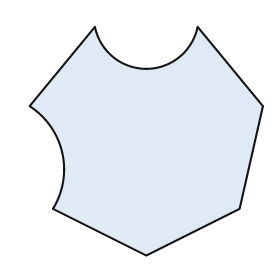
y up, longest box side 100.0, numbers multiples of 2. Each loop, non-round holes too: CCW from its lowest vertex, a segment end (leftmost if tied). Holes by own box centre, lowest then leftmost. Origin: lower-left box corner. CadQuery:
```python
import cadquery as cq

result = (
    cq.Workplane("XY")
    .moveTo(50.0, 0.0)
    .lineTo(90.0, 20.0)
    .lineTo(100.0, 64.0)
    .lineTo(72.0, 98.0)
    .threePointArc((50.0, 80.0), (28.0, 98.0))
    .lineTo(0.0, 64.0)
    .threePointArc((14.0, 44.0), (10.0, 20.0))
    .close()
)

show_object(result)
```